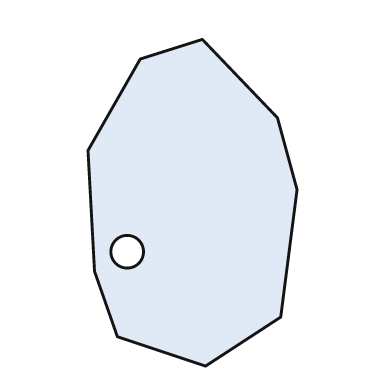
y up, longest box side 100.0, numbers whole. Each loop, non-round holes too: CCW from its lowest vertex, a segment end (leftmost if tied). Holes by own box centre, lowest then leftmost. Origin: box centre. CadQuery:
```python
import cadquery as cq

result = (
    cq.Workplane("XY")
    .moveTo(4.0, -50.0)
    .lineTo(27.0, -35.0)
    .lineTo(32.0, 4.0)
    .lineTo(26.0, 26.0)
    .lineTo(3.0, 50.0)
    .lineTo(-16.0, 44.0)
    .lineTo(-32.0, 16.0)
    .lineTo(-30.0, -21.0)
    .lineTo(-23.0, -41.0)
    .close()
    .moveTo(-20.0, -15.0)
    .circle(5.0)
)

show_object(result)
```